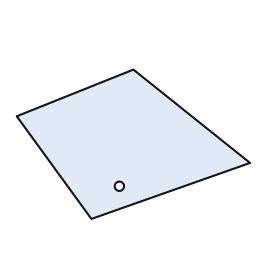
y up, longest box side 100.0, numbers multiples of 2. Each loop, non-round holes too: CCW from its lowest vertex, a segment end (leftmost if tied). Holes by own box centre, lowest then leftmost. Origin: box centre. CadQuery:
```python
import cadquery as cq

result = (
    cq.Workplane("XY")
    .moveTo(-18.0, -32.0)
    .lineTo(50.0, -8.0)
    .lineTo(0.0, 32.0)
    .lineTo(-50.0, 12.0)
    .close()
    .moveTo(-6.0, -18.0)
    .circle(2.0)
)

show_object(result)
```